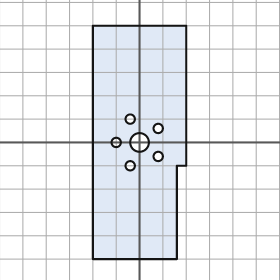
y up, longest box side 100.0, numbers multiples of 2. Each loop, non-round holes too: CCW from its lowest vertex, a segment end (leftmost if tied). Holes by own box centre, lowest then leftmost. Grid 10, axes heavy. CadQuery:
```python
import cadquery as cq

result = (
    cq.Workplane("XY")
    .moveTo(-20.0, -50.0)
    .lineTo(16.0, -50.0)
    .lineTo(16.0, -10.0)
    .lineTo(20.0, -10.0)
    .lineTo(20.0, 50.0)
    .lineTo(-20.0, 50.0)
    .close()
    .moveTo(-4.0, -10.0)
    .circle(2.0)
    .moveTo(8.0, -6.0)
    .circle(2.0)
    .moveTo(-10.0, 0.0)
    .circle(2.0)
    .moveTo(0.0, 0.0)
    .circle(4.0)
    .moveTo(8.0, 6.0)
    .circle(2.0)
    .moveTo(-4.0, 10.0)
    .circle(2.0)
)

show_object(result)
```